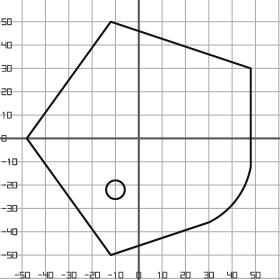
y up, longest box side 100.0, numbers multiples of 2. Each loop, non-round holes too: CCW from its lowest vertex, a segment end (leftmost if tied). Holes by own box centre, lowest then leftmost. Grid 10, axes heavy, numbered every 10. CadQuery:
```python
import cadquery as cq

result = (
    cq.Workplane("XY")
    .moveTo(-12.0, -50.0)
    .lineTo(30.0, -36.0)
    .threePointArc((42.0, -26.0), (48.0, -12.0))
    .lineTo(48.0, 30.0)
    .lineTo(-12.0, 50.0)
    .lineTo(-48.0, 0.0)
    .close()
    .moveTo(-10.0, -22.0)
    .circle(4.0)
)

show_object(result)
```